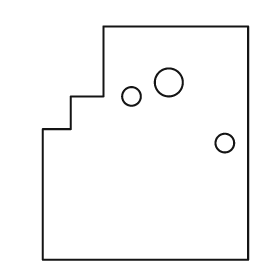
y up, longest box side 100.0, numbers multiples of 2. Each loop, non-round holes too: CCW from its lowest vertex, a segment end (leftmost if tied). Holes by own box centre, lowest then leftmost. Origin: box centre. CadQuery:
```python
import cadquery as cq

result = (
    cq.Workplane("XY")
    .moveTo(-44.0, -50.0)
    .lineTo(44.0, -50.0)
    .lineTo(44.0, 50.0)
    .lineTo(-18.0, 50.0)
    .lineTo(-18.0, 20.0)
    .lineTo(-32.0, 20.0)
    .lineTo(-32.0, 6.0)
    .lineTo(-44.0, 6.0)
    .close()
    .moveTo(34.0, 0.0)
    .circle(4.0)
    .moveTo(-6.0, 20.0)
    .circle(4.0)
    .moveTo(10.0, 26.0)
    .circle(6.0)
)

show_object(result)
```